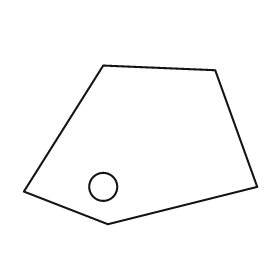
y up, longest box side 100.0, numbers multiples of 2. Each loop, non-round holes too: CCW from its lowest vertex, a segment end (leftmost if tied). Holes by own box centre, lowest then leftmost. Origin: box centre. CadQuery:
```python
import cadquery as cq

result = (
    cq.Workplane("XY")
    .moveTo(-14.0, -34.0)
    .lineTo(50.0, -18.0)
    .lineTo(32.0, 32.0)
    .lineTo(-16.0, 34.0)
    .lineTo(-50.0, -20.0)
    .close()
    .moveTo(-16.0, -18.0)
    .circle(6.0)
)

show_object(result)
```